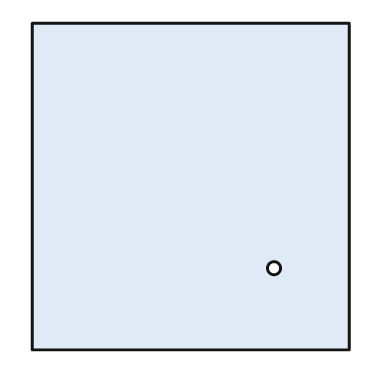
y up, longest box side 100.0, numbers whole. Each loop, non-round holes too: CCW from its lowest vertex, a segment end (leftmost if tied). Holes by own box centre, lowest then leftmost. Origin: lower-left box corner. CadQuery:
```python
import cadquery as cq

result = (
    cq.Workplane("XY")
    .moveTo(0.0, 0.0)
    .lineTo(97.0, 0.0)
    .lineTo(97.0, 100.0)
    .lineTo(0.0, 100.0)
    .close()
    .moveTo(74.0, 25.0)
    .circle(2.0)
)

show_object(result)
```